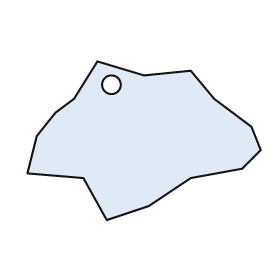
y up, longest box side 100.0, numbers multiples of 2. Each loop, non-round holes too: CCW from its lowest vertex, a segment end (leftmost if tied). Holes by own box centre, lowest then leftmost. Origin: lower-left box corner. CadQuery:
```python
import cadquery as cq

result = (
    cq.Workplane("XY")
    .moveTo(34.0, 0.0)
    .lineTo(52.0, 6.0)
    .lineTo(70.0, 18.0)
    .lineTo(92.0, 22.0)
    .lineTo(100.0, 30.0)
    .lineTo(96.0, 40.0)
    .lineTo(80.0, 52.0)
    .lineTo(70.0, 64.0)
    .lineTo(50.0, 62.0)
    .lineTo(30.0, 68.0)
    .lineTo(20.0, 52.0)
    .lineTo(12.0, 46.0)
    .lineTo(4.0, 36.0)
    .lineTo(0.0, 20.0)
    .lineTo(24.0, 18.0)
    .close()
    .moveTo(36.0, 58.0)
    .circle(4.0)
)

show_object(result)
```